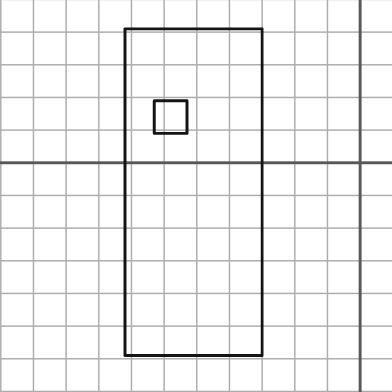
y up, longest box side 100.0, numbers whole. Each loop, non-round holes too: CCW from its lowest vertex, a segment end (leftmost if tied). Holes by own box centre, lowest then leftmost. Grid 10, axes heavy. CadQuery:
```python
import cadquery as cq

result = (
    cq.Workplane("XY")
    .moveTo(-72.0, -59.0)
    .lineTo(-30.0, -59.0)
    .lineTo(-30.0, 41.0)
    .lineTo(-72.0, 41.0)
    .close()
    .moveTo(-63.0, 9.0)
    .lineTo(-53.0, 9.0)
    .lineTo(-53.0, 19.0)
    .lineTo(-63.0, 19.0)
    .close()
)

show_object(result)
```